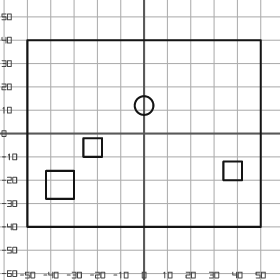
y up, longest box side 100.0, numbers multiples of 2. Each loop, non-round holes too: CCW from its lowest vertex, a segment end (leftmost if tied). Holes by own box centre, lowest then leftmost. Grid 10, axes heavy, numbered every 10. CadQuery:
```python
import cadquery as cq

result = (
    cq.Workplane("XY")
    .moveTo(-50.0, -40.0)
    .lineTo(50.0, -40.0)
    .lineTo(50.0, 40.0)
    .lineTo(-50.0, 40.0)
    .close()
    .moveTo(-42.0, -28.0)
    .lineTo(-30.0, -28.0)
    .lineTo(-30.0, -16.0)
    .lineTo(-42.0, -16.0)
    .close()
    .moveTo(34.0, -20.0)
    .lineTo(42.0, -20.0)
    .lineTo(42.0, -12.0)
    .lineTo(34.0, -12.0)
    .close()
    .moveTo(-26.0, -10.0)
    .lineTo(-18.0, -10.0)
    .lineTo(-18.0, -2.0)
    .lineTo(-26.0, -2.0)
    .close()
    .moveTo(0.0, 12.0)
    .circle(4.0)
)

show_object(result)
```